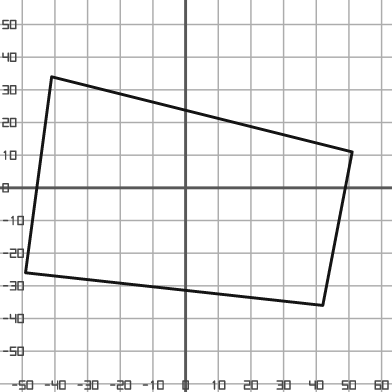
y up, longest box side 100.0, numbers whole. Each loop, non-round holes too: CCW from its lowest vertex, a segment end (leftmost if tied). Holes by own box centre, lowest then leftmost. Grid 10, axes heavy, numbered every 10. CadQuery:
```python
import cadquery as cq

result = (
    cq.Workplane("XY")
    .moveTo(42.0, -36.0)
    .lineTo(51.0, 11.0)
    .lineTo(-41.0, 34.0)
    .lineTo(-49.0, -26.0)
    .close()
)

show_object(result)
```